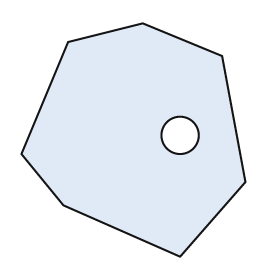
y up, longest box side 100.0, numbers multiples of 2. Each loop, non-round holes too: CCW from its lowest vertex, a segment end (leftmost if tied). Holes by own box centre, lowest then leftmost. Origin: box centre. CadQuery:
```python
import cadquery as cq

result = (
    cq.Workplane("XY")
    .moveTo(20.0, -50.0)
    .lineTo(48.0, -18.0)
    .lineTo(38.0, 36.0)
    .lineTo(4.0, 50.0)
    .lineTo(-28.0, 42.0)
    .lineTo(-48.0, -6.0)
    .lineTo(-30.0, -28.0)
    .close()
    .moveTo(20.0, 2.0)
    .circle(8.0)
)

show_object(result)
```